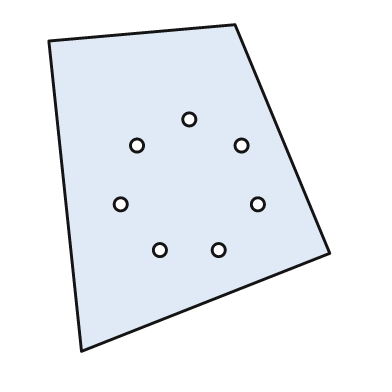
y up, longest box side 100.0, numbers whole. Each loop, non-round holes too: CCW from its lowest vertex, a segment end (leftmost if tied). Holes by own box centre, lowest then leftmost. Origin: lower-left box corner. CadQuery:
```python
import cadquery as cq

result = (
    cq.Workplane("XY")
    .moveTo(10.0, 0.0)
    .lineTo(86.0, 30.0)
    .lineTo(57.0, 100.0)
    .lineTo(0.0, 95.0)
    .close()
    .moveTo(34.0, 31.0)
    .circle(2.0)
    .moveTo(52.0, 31.0)
    .circle(2.0)
    .moveTo(22.0, 45.0)
    .circle(2.0)
    .moveTo(64.0, 45.0)
    .circle(2.0)
    .moveTo(27.0, 63.0)
    .circle(2.0)
    .moveTo(59.0, 63.0)
    .circle(2.0)
    .moveTo(43.0, 71.0)
    .circle(2.0)
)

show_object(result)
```